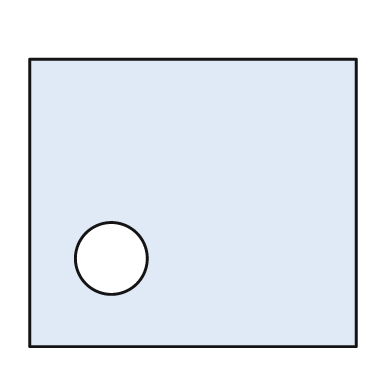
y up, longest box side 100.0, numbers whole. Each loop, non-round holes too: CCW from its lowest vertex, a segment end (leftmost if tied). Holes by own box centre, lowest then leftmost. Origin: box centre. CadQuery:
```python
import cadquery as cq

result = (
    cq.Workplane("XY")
    .moveTo(-50.0, -44.0)
    .lineTo(50.0, -44.0)
    .lineTo(50.0, 44.0)
    .lineTo(-50.0, 44.0)
    .close()
    .moveTo(-25.0, -17.0)
    .circle(11.0)
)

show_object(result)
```